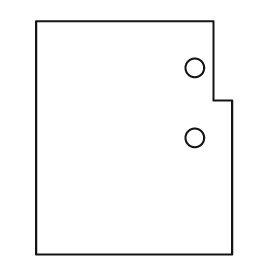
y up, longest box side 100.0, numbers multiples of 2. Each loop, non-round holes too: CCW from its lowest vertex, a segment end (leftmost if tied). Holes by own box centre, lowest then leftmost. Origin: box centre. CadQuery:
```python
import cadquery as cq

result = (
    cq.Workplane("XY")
    .moveTo(-42.0, -50.0)
    .lineTo(42.0, -50.0)
    .lineTo(42.0, 16.0)
    .lineTo(34.0, 16.0)
    .lineTo(34.0, 50.0)
    .lineTo(-42.0, 50.0)
    .close()
    .moveTo(26.0, 0.0)
    .circle(4.0)
    .moveTo(26.0, 30.0)
    .circle(4.0)
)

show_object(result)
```